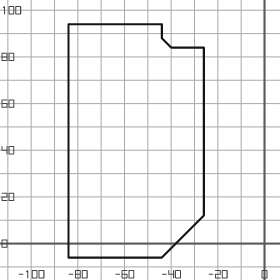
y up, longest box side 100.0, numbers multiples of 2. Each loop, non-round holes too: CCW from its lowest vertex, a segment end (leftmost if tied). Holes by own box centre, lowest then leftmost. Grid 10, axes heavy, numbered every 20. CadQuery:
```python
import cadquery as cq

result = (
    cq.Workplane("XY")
    .moveTo(-84.0, -6.0)
    .lineTo(-44.0, -6.0)
    .lineTo(-26.0, 12.0)
    .lineTo(-26.0, 84.0)
    .lineTo(-40.0, 84.0)
    .lineTo(-44.0, 88.0)
    .lineTo(-44.0, 94.0)
    .lineTo(-84.0, 94.0)
    .close()
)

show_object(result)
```